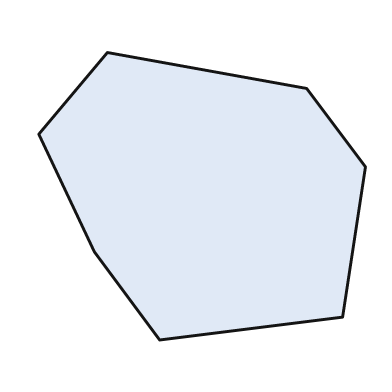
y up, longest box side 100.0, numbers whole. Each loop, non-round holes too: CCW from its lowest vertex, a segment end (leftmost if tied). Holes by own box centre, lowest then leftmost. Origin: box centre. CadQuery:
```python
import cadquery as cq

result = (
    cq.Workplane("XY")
    .moveTo(-13.0, -44.0)
    .lineTo(43.0, -37.0)
    .lineTo(50.0, 9.0)
    .lineTo(32.0, 33.0)
    .lineTo(-29.0, 44.0)
    .lineTo(-50.0, 19.0)
    .lineTo(-33.0, -17.0)
    .close()
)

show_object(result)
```